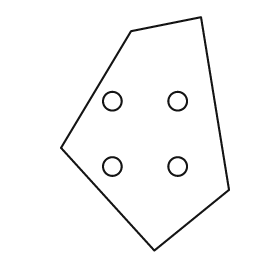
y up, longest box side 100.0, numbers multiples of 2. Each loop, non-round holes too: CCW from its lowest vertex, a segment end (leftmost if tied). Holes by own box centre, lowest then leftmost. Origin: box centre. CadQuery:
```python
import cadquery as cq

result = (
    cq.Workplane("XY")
    .moveTo(4.0, -50.0)
    .lineTo(36.0, -24.0)
    .lineTo(24.0, 50.0)
    .lineTo(-6.0, 44.0)
    .lineTo(-36.0, -6.0)
    .close()
    .moveTo(-14.0, -14.0)
    .circle(4.0)
    .moveTo(14.0, -14.0)
    .circle(4.0)
    .moveTo(-14.0, 14.0)
    .circle(4.0)
    .moveTo(14.0, 14.0)
    .circle(4.0)
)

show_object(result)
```